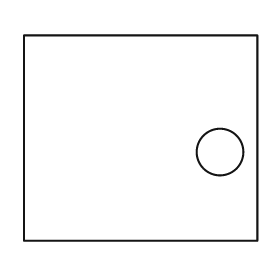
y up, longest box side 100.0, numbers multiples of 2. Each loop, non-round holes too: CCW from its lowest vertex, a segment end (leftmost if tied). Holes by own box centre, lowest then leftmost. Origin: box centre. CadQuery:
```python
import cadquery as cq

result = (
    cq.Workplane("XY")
    .moveTo(-50.0, -44.0)
    .lineTo(50.0, -44.0)
    .lineTo(50.0, 44.0)
    .lineTo(-50.0, 44.0)
    .close()
    .moveTo(34.0, -6.0)
    .circle(10.0)
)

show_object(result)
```